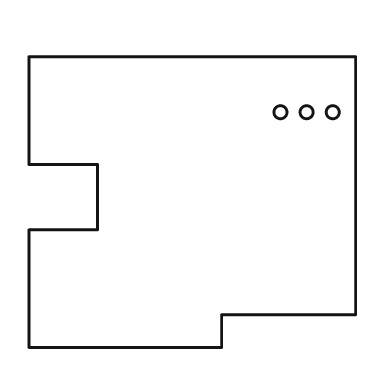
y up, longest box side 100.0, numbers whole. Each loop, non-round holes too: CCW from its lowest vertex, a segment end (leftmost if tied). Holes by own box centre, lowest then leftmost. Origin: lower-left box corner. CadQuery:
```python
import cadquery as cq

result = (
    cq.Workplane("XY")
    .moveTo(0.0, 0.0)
    .lineTo(59.0, 0.0)
    .lineTo(59.0, 10.0)
    .lineTo(100.0, 10.0)
    .lineTo(100.0, 89.0)
    .lineTo(0.0, 89.0)
    .lineTo(0.0, 56.0)
    .lineTo(21.0, 56.0)
    .lineTo(21.0, 36.0)
    .lineTo(0.0, 36.0)
    .close()
    .moveTo(77.0, 72.0)
    .circle(2.0)
    .moveTo(85.0, 72.0)
    .circle(2.0)
    .moveTo(93.0, 72.0)
    .circle(2.0)
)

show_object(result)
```